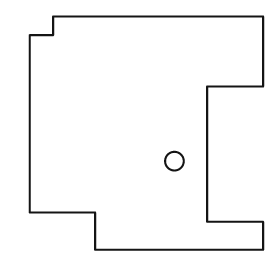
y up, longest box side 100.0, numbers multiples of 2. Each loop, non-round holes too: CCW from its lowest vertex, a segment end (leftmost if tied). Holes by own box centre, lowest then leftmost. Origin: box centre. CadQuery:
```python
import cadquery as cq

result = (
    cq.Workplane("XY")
    .moveTo(-22.0, -50.0)
    .lineTo(50.0, -50.0)
    .lineTo(50.0, -38.0)
    .lineTo(26.0, -38.0)
    .lineTo(26.0, 20.0)
    .lineTo(50.0, 20.0)
    .lineTo(50.0, 50.0)
    .lineTo(-40.0, 50.0)
    .lineTo(-40.0, 42.0)
    .lineTo(-50.0, 42.0)
    .lineTo(-50.0, -34.0)
    .lineTo(-22.0, -34.0)
    .close()
    .moveTo(12.0, -12.0)
    .circle(4.0)
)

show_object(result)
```